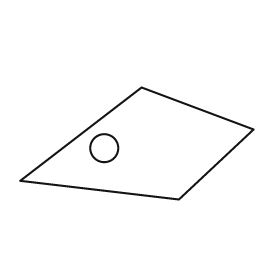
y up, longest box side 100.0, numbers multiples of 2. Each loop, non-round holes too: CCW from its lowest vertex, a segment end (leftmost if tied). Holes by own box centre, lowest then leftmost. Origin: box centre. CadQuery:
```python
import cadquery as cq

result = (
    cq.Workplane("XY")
    .moveTo(18.0, -24.0)
    .lineTo(50.0, 6.0)
    .lineTo(2.0, 24.0)
    .lineTo(-50.0, -16.0)
    .close()
    .moveTo(-14.0, -2.0)
    .circle(6.0)
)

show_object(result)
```